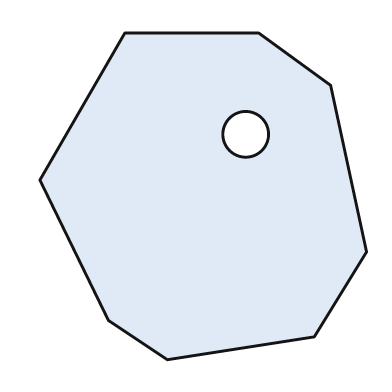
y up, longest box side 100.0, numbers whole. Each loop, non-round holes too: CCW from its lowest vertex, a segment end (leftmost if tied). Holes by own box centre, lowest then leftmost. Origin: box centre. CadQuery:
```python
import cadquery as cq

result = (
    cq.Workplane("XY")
    .moveTo(-11.0, -50.0)
    .lineTo(34.0, -43.0)
    .lineTo(50.0, -17.0)
    .lineTo(39.0, 34.0)
    .lineTo(17.0, 50.0)
    .lineTo(-24.0, 50.0)
    .lineTo(-50.0, 5.0)
    .lineTo(-29.0, -38.0)
    .close()
    .moveTo(13.0, 19.0)
    .circle(7.0)
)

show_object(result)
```